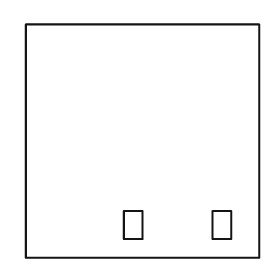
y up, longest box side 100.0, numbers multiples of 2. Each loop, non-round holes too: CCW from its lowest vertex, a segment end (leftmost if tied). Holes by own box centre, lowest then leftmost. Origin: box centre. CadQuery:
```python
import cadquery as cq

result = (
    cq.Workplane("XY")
    .moveTo(-50.0, -50.0)
    .lineTo(50.0, -50.0)
    .lineTo(50.0, 50.0)
    .lineTo(-50.0, 50.0)
    .close()
    .moveTo(-8.0, -42.0)
    .lineTo(0.0, -42.0)
    .lineTo(0.0, -30.0)
    .lineTo(-8.0, -30.0)
    .close()
    .moveTo(30.0, -42.0)
    .lineTo(38.0, -42.0)
    .lineTo(38.0, -30.0)
    .lineTo(30.0, -30.0)
    .close()
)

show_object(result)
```